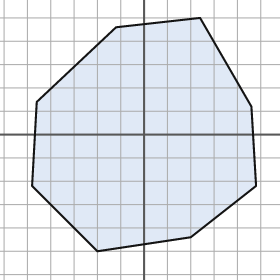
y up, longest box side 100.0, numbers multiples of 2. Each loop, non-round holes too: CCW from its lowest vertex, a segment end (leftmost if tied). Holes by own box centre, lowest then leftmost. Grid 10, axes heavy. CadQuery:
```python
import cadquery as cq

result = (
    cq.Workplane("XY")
    .moveTo(-20.0, -50.0)
    .lineTo(20.0, -44.0)
    .lineTo(48.0, -22.0)
    .lineTo(46.0, 12.0)
    .lineTo(24.0, 50.0)
    .lineTo(-12.0, 46.0)
    .lineTo(-46.0, 14.0)
    .lineTo(-48.0, -22.0)
    .close()
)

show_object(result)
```